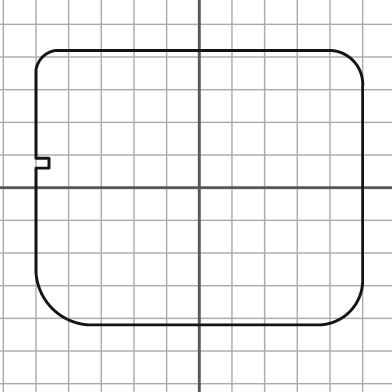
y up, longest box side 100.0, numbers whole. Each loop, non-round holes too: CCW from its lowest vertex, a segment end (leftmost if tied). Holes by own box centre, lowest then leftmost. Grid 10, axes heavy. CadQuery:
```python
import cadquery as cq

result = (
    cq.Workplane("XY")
    .moveTo(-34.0, -42.0)
    .lineTo(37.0, -42.0)
    .threePointArc((46.0, -38.0), (50.0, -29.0))
    .lineTo(50.0, 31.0)
    .threePointArc((47.0, 39.0), (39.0, 42.0))
    .lineTo(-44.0, 42.0)
    .threePointArc((-48.0, 40.0), (-50.0, 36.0))
    .lineTo(-50.0, 9.0)
    .lineTo(-46.0, 9.0)
    .lineTo(-46.0, 6.0)
    .lineTo(-50.0, 6.0)
    .lineTo(-50.0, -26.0)
    .threePointArc((-45.0, -37.0), (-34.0, -42.0))
    .close()
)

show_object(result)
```